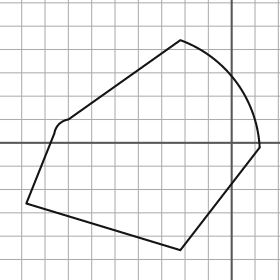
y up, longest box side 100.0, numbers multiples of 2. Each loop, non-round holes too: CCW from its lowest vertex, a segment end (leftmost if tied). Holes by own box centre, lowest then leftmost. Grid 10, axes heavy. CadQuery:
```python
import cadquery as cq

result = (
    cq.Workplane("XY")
    .moveTo(-22.0, -46.0)
    .lineTo(12.0, -2.0)
    .threePointArc((2.0, 26.0), (-22.0, 44.0))
    .lineTo(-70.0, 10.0)
    .threePointArc((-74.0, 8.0), (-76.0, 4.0))
    .lineTo(-88.0, -26.0)
    .close()
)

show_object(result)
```